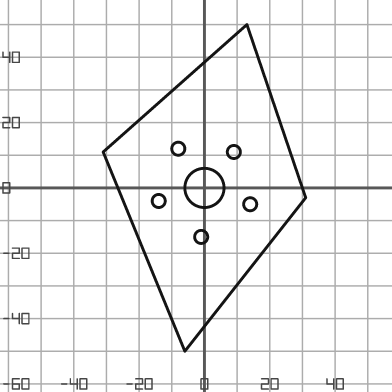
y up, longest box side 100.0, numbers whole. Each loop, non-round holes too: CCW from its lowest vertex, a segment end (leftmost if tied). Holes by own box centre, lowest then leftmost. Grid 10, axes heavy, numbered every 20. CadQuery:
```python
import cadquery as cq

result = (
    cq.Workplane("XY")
    .moveTo(-6.0, -50.0)
    .lineTo(31.0, -3.0)
    .lineTo(13.0, 50.0)
    .lineTo(-31.0, 11.0)
    .close()
    .moveTo(-1.0, -15.0)
    .circle(2.0)
    .moveTo(14.0, -5.0)
    .circle(2.0)
    .moveTo(-14.0, -4.0)
    .circle(2.0)
    .moveTo(0.0, 0.0)
    .circle(6.0)
    .moveTo(9.0, 11.0)
    .circle(2.0)
    .moveTo(-8.0, 12.0)
    .circle(2.0)
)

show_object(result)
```